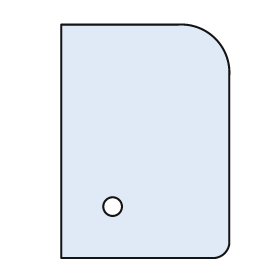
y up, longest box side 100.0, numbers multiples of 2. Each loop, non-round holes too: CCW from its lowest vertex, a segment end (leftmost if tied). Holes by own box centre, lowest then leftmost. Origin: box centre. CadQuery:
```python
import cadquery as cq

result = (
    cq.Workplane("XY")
    .moveTo(-36.0, -50.0)
    .lineTo(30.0, -50.0)
    .threePointArc((34.0, -48.0), (36.0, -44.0))
    .lineTo(36.0, 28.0)
    .threePointArc((30.0, 44.0), (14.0, 50.0))
    .lineTo(-36.0, 50.0)
    .close()
    .moveTo(-14.0, -28.0)
    .circle(4.0)
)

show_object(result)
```